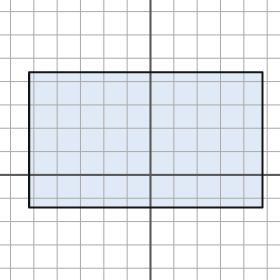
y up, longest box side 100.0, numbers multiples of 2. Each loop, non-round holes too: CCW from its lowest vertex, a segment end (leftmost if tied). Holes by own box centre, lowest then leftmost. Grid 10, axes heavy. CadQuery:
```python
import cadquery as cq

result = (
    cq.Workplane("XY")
    .moveTo(-52.0, -14.0)
    .lineTo(48.0, -14.0)
    .lineTo(48.0, 44.0)
    .lineTo(-52.0, 44.0)
    .close()
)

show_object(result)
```